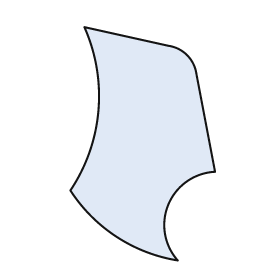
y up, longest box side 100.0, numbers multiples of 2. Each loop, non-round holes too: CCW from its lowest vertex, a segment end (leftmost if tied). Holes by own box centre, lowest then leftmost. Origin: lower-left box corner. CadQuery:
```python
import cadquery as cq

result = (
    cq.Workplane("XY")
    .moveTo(46.0, 0.0)
    .threePointArc((42.0, 24.0), (62.0, 38.0))
    .lineTo(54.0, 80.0)
    .threePointArc((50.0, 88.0), (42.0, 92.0))
    .lineTo(6.0, 100.0)
    .threePointArc((12.0, 64.0), (0.0, 30.0))
    .threePointArc((20.0, 10.0), (46.0, 0.0))
    .close()
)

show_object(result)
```